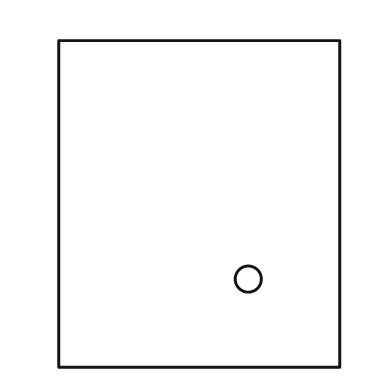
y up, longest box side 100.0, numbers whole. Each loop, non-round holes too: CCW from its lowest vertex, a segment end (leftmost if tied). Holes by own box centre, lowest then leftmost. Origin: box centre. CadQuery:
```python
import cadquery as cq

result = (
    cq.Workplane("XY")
    .moveTo(-43.0, -50.0)
    .lineTo(43.0, -50.0)
    .lineTo(43.0, 50.0)
    .lineTo(-43.0, 50.0)
    .close()
    .moveTo(15.0, -23.0)
    .circle(4.0)
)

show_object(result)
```